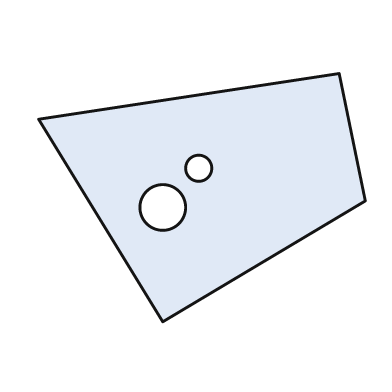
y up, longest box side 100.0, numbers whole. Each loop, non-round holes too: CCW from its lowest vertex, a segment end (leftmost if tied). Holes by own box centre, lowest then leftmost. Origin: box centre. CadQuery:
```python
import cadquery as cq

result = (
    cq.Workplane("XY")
    .moveTo(-12.0, -38.0)
    .lineTo(50.0, -1.0)
    .lineTo(42.0, 38.0)
    .lineTo(-50.0, 24.0)
    .close()
    .moveTo(-12.0, -3.0)
    .circle(7.0)
    .moveTo(-1.0, 9.0)
    .circle(4.0)
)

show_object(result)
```